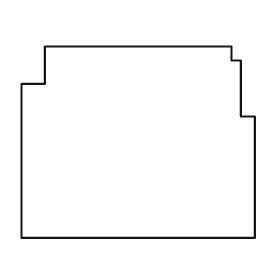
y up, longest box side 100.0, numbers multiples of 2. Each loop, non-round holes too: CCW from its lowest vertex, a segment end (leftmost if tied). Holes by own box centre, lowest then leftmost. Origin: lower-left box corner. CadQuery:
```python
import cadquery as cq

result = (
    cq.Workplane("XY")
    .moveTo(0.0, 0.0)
    .lineTo(100.0, 0.0)
    .lineTo(100.0, 52.0)
    .lineTo(94.0, 52.0)
    .lineTo(94.0, 76.0)
    .lineTo(90.0, 76.0)
    .lineTo(90.0, 82.0)
    .lineTo(10.0, 82.0)
    .lineTo(10.0, 66.0)
    .lineTo(0.0, 66.0)
    .close()
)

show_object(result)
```